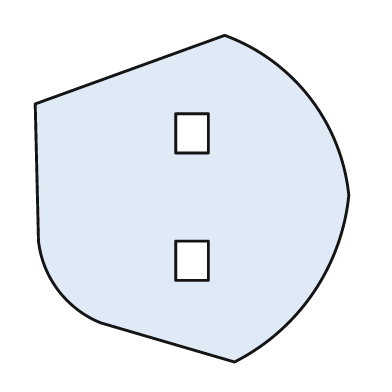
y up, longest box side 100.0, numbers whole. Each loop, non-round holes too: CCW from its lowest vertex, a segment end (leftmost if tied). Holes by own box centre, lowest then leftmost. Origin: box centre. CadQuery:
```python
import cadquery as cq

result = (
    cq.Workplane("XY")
    .moveTo(13.0, -50.0)
    .threePointArc((37.0, -29.0), (48.0, 1.0))
    .threePointArc((36.0, 31.0), (10.0, 50.0))
    .lineTo(-48.0, 29.0)
    .lineTo(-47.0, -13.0)
    .threePointArc((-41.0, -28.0), (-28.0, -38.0))
    .close()
    .moveTo(-5.0, -25.0)
    .lineTo(5.0, -25.0)
    .lineTo(5.0, -13.0)
    .lineTo(-5.0, -13.0)
    .close()
    .moveTo(-5.0, 14.0)
    .lineTo(5.0, 14.0)
    .lineTo(5.0, 26.0)
    .lineTo(-5.0, 26.0)
    .close()
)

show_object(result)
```